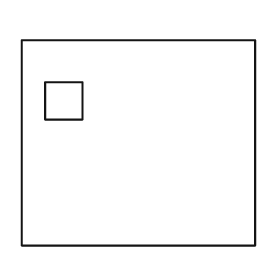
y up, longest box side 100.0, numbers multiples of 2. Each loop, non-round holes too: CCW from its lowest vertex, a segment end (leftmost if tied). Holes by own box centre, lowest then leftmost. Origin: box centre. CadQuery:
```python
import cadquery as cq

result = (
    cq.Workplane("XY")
    .moveTo(-50.0, -44.0)
    .lineTo(50.0, -44.0)
    .lineTo(50.0, 44.0)
    .lineTo(-50.0, 44.0)
    .close()
    .moveTo(-40.0, 10.0)
    .lineTo(-24.0, 10.0)
    .lineTo(-24.0, 26.0)
    .lineTo(-40.0, 26.0)
    .close()
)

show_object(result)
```